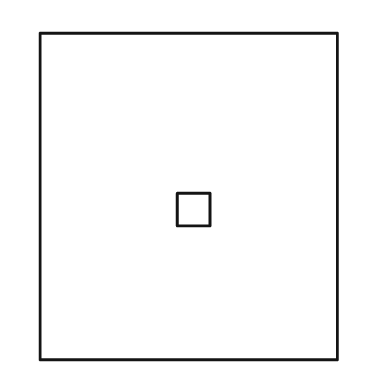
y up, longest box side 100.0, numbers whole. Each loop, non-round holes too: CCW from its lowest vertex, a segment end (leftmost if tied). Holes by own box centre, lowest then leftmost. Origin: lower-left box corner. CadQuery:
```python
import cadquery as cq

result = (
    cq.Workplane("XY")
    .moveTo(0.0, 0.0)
    .lineTo(91.0, 0.0)
    .lineTo(91.0, 100.0)
    .lineTo(0.0, 100.0)
    .close()
    .moveTo(42.0, 41.0)
    .lineTo(52.0, 41.0)
    .lineTo(52.0, 51.0)
    .lineTo(42.0, 51.0)
    .close()
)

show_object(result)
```